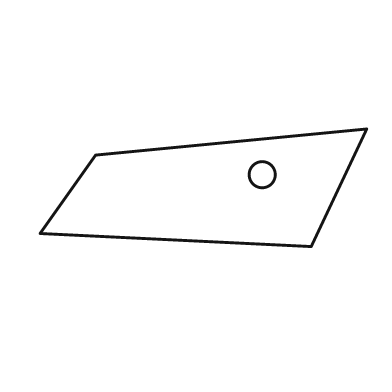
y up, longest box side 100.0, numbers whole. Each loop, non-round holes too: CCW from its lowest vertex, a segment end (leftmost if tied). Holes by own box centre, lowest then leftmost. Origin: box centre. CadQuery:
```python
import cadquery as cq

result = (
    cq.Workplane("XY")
    .moveTo(33.0, -18.0)
    .lineTo(50.0, 18.0)
    .lineTo(-33.0, 10.0)
    .lineTo(-50.0, -14.0)
    .close()
    .moveTo(18.0, 4.0)
    .circle(4.0)
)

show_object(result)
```